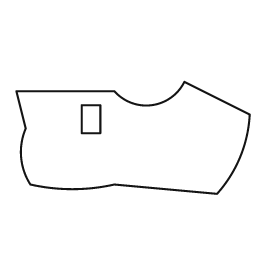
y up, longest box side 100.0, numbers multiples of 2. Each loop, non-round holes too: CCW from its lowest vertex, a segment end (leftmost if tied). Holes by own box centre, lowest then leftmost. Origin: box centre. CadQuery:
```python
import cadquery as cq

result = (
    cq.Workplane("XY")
    .moveTo(36.0, -24.0)
    .threePointArc((46.0, -8.0), (50.0, 10.0))
    .lineTo(22.0, 24.0)
    .threePointArc((8.0, 14.0), (-8.0, 20.0))
    .lineTo(-50.0, 20.0)
    .lineTo(-46.0, 4.0)
    .threePointArc((-48.0, -8.0), (-44.0, -20.0))
    .threePointArc((-26.0, -22.0), (-8.0, -20.0))
    .close()
    .moveTo(-22.0, 2.0)
    .lineTo(-14.0, 2.0)
    .lineTo(-14.0, 14.0)
    .lineTo(-22.0, 14.0)
    .close()
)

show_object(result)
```